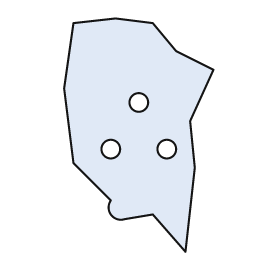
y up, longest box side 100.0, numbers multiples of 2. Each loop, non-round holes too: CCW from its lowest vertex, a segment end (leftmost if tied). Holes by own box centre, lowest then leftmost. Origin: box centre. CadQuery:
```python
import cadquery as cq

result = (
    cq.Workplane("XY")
    .moveTo(20.0, -50.0)
    .lineTo(24.0, -14.0)
    .lineTo(22.0, 6.0)
    .lineTo(32.0, 28.0)
    .lineTo(16.0, 36.0)
    .lineTo(6.0, 48.0)
    .lineTo(-10.0, 50.0)
    .lineTo(-28.0, 48.0)
    .lineTo(-32.0, 20.0)
    .lineTo(-28.0, -12.0)
    .lineTo(-12.0, -28.0)
    .threePointArc((-12.0, -34.0), (-6.0, -36.0))
    .lineTo(6.0, -34.0)
    .close()
    .moveTo(-12.0, -6.0)
    .circle(4.0)
    .moveTo(12.0, -6.0)
    .circle(4.0)
    .moveTo(0.0, 14.0)
    .circle(4.0)
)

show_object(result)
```